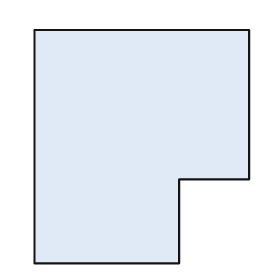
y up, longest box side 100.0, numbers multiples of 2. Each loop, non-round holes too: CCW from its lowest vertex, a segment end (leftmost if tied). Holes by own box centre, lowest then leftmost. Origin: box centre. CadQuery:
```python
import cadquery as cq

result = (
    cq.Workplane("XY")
    .moveTo(-46.0, -50.0)
    .lineTo(16.0, -50.0)
    .lineTo(16.0, -14.0)
    .lineTo(46.0, -14.0)
    .lineTo(46.0, 50.0)
    .lineTo(-46.0, 50.0)
    .close()
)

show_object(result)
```